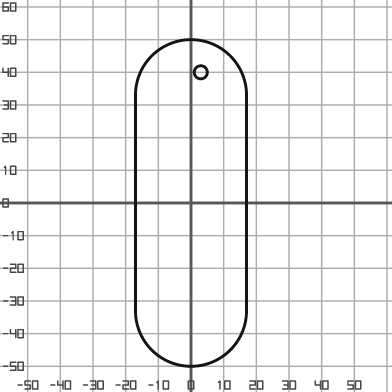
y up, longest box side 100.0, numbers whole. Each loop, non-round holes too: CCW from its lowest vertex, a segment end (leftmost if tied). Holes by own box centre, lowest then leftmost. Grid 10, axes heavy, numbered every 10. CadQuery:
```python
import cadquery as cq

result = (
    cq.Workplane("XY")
    .moveTo(-17.0, -33.0)
    .threePointArc((0.0, -50.0), (17.0, -33.0))
    .lineTo(17.0, 33.0)
    .threePointArc((0.0, 50.0), (-17.0, 33.0))
    .close()
    .moveTo(3.0, 40.0)
    .circle(2.0)
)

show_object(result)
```